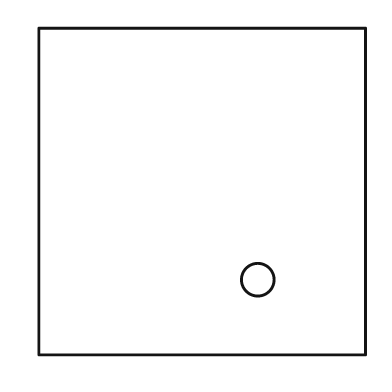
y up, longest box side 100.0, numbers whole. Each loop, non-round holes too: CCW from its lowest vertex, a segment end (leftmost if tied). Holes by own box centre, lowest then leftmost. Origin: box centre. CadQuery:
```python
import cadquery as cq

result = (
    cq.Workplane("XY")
    .moveTo(-50.0, -50.0)
    .lineTo(50.0, -50.0)
    .lineTo(50.0, 50.0)
    .lineTo(-50.0, 50.0)
    .close()
    .moveTo(17.0, -27.0)
    .circle(5.0)
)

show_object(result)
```